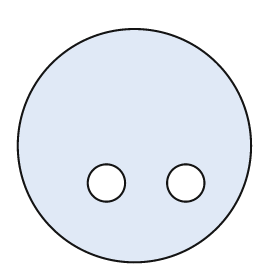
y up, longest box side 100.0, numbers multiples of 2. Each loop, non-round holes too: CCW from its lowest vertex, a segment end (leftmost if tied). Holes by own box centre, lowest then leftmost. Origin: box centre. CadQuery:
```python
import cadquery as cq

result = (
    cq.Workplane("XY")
    .moveTo(0.0, 0.0)
    .circle(50.0)
    .moveTo(-12.0, -16.0)
    .circle(8.0)
    .moveTo(22.0, -16.0)
    .circle(8.0)
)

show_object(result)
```